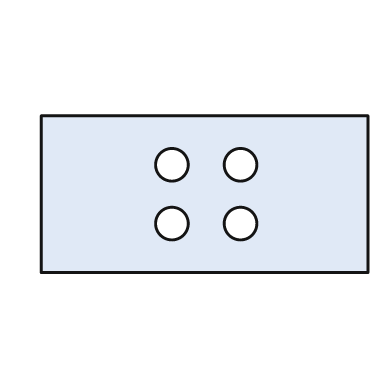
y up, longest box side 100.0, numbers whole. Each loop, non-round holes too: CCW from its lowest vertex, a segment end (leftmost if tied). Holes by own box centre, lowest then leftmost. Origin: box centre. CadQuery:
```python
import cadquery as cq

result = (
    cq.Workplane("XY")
    .moveTo(-50.0, -24.0)
    .lineTo(50.0, -24.0)
    .lineTo(50.0, 24.0)
    .lineTo(-50.0, 24.0)
    .close()
    .moveTo(-10.0, -9.0)
    .circle(5.0)
    .moveTo(11.0, -9.0)
    .circle(5.0)
    .moveTo(-10.0, 9.0)
    .circle(5.0)
    .moveTo(11.0, 9.0)
    .circle(5.0)
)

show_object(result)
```